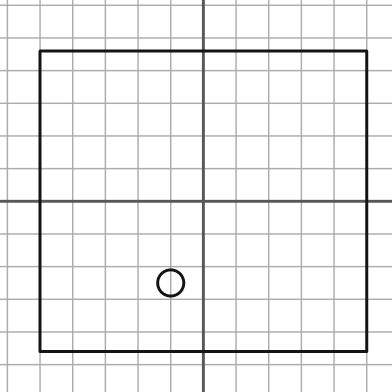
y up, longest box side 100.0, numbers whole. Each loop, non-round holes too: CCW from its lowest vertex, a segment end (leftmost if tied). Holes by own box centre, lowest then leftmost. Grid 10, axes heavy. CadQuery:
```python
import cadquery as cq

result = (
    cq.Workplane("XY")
    .moveTo(-50.0, -46.0)
    .lineTo(50.0, -46.0)
    .lineTo(50.0, 46.0)
    .lineTo(-50.0, 46.0)
    .close()
    .moveTo(-10.0, -25.0)
    .circle(4.0)
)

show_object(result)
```